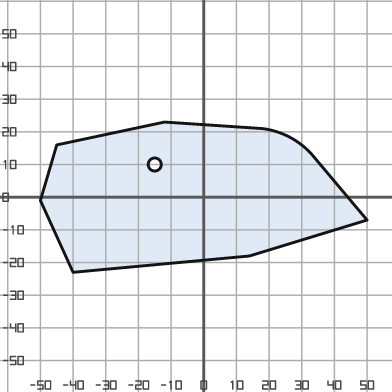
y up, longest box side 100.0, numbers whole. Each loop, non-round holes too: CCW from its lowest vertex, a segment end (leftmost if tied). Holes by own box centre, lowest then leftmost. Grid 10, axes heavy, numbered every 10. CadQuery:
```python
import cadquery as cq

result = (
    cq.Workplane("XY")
    .moveTo(-40.0, -23.0)
    .lineTo(14.0, -18.0)
    .lineTo(50.0, -7.0)
    .lineTo(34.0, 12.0)
    .threePointArc((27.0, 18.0), (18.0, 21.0))
    .lineTo(-12.0, 23.0)
    .lineTo(-45.0, 16.0)
    .lineTo(-50.0, -1.0)
    .close()
    .moveTo(-15.0, 10.0)
    .circle(2.0)
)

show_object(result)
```